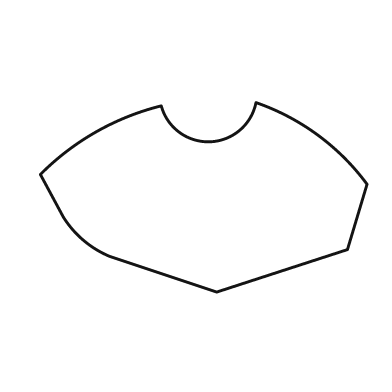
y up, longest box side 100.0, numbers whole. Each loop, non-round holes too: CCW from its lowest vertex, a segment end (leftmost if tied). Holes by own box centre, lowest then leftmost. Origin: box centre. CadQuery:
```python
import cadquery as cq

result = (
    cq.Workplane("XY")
    .moveTo(4.0, -29.0)
    .lineTo(44.0, -16.0)
    .lineTo(50.0, 4.0)
    .threePointArc((35.0, 19.0), (16.0, 29.0))
    .threePointArc((2.0, 17.0), (-13.0, 28.0))
    .threePointArc((-33.0, 20.0), (-50.0, 7.0))
    .lineTo(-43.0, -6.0)
    .threePointArc((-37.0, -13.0), (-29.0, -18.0))
    .close()
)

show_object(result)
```